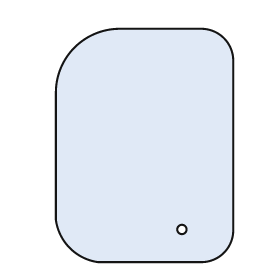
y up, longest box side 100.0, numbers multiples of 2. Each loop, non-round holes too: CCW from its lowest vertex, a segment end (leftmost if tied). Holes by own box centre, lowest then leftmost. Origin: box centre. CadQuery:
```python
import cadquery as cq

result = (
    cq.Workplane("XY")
    .moveTo(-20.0, -50.0)
    .lineTo(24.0, -50.0)
    .threePointArc((34.0, -46.0), (38.0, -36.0))
    .lineTo(38.0, 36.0)
    .threePointArc((34.0, 46.0), (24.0, 50.0))
    .lineTo(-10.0, 50.0)
    .threePointArc((-30.0, 42.0), (-38.0, 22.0))
    .lineTo(-38.0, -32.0)
    .threePointArc((-32.0, -44.0), (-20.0, -50.0))
    .close()
    .moveTo(16.0, -36.0)
    .circle(2.0)
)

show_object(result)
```